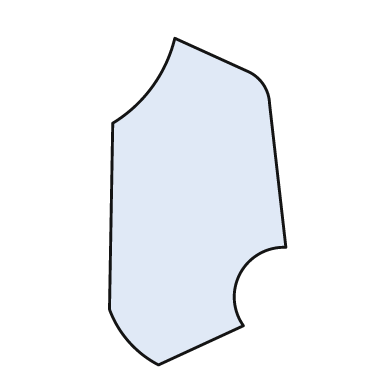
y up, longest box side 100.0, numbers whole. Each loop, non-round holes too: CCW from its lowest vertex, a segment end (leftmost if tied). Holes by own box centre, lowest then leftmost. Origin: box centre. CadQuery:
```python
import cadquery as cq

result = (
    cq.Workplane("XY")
    .moveTo(-12.0, -50.0)
    .lineTo(14.0, -38.0)
    .threePointArc((13.0, -22.0), (27.0, -14.0))
    .lineTo(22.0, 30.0)
    .threePointArc((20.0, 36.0), (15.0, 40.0))
    .lineTo(-7.0, 50.0)
    .threePointArc((-14.0, 35.0), (-26.0, 24.0))
    .lineTo(-27.0, -33.0)
    .threePointArc((-21.0, -43.0), (-12.0, -50.0))
    .close()
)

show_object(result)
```